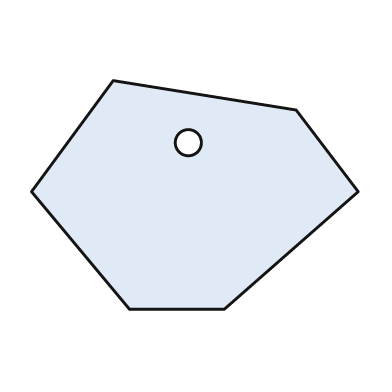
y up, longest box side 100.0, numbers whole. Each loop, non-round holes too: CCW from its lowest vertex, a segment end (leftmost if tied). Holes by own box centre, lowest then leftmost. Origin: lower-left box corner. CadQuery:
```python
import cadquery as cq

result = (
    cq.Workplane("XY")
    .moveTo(30.0, 0.0)
    .lineTo(59.0, 0.0)
    .lineTo(100.0, 36.0)
    .lineTo(81.0, 61.0)
    .lineTo(25.0, 70.0)
    .lineTo(0.0, 36.0)
    .close()
    .moveTo(48.0, 51.0)
    .circle(4.0)
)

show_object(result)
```